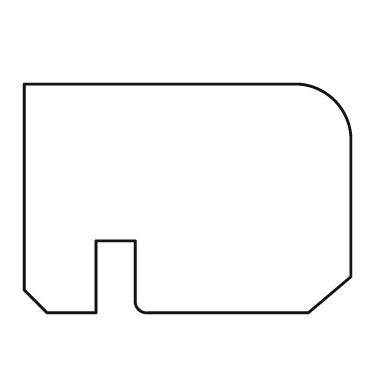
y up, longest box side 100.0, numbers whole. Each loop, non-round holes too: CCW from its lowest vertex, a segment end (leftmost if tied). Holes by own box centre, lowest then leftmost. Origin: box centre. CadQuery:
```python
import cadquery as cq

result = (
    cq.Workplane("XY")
    .moveTo(-43.0, -35.0)
    .lineTo(-28.0, -35.0)
    .lineTo(-28.0, -13.0)
    .lineTo(-16.0, -13.0)
    .lineTo(-16.0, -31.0)
    .threePointArc((-15.0, -34.0), (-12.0, -35.0))
    .lineTo(37.0, -35.0)
    .lineTo(50.0, -24.0)
    .lineTo(50.0, 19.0)
    .threePointArc((45.0, 30.0), (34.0, 35.0))
    .lineTo(-50.0, 35.0)
    .lineTo(-50.0, -28.0)
    .close()
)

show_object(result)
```